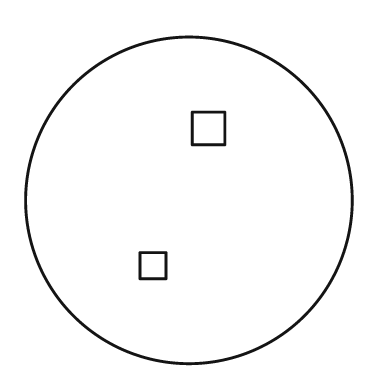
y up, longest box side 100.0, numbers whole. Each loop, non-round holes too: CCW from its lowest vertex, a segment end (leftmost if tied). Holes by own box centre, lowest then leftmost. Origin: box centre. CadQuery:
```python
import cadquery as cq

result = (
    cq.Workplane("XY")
    .moveTo(0.0, 0.0)
    .circle(50.0)
    .moveTo(-15.0, -24.0)
    .lineTo(-7.0, -24.0)
    .lineTo(-7.0, -16.0)
    .lineTo(-15.0, -16.0)
    .close()
    .moveTo(1.0, 17.0)
    .lineTo(11.0, 17.0)
    .lineTo(11.0, 27.0)
    .lineTo(1.0, 27.0)
    .close()
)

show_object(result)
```